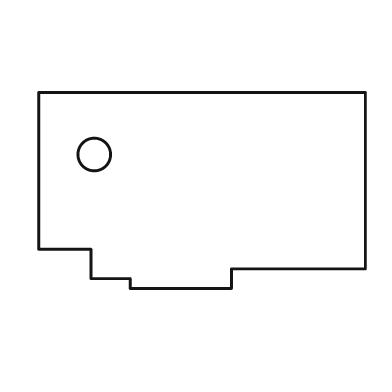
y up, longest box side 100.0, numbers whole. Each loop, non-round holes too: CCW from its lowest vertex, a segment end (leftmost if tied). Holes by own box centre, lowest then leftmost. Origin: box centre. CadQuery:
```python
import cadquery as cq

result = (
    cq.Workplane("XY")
    .moveTo(-22.0, -30.0)
    .lineTo(9.0, -30.0)
    .lineTo(9.0, -24.0)
    .lineTo(50.0, -24.0)
    .lineTo(50.0, 30.0)
    .lineTo(-50.0, 30.0)
    .lineTo(-50.0, -18.0)
    .lineTo(-34.0, -18.0)
    .lineTo(-34.0, -27.0)
    .lineTo(-22.0, -27.0)
    .close()
    .moveTo(-33.0, 11.0)
    .circle(5.0)
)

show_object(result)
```